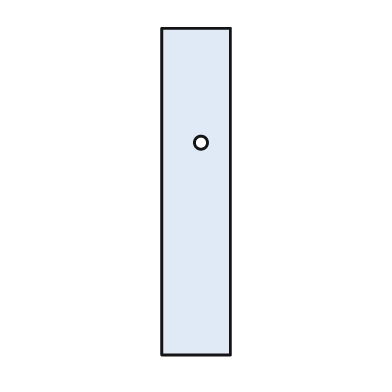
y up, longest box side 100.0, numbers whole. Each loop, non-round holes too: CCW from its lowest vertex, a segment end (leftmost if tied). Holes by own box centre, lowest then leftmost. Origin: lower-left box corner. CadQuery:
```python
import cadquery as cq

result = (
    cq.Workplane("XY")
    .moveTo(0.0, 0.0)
    .lineTo(21.0, 0.0)
    .lineTo(21.0, 100.0)
    .lineTo(0.0, 100.0)
    .close()
    .moveTo(12.0, 65.0)
    .circle(2.0)
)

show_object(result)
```